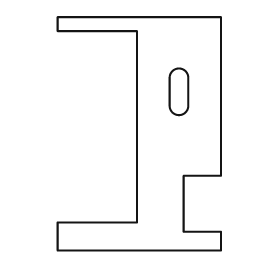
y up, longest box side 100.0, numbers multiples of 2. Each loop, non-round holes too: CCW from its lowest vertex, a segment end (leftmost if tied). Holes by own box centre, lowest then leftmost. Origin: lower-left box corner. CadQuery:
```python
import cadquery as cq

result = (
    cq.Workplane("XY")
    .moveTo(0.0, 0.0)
    .lineTo(70.0, 0.0)
    .lineTo(70.0, 8.0)
    .lineTo(54.0, 8.0)
    .lineTo(54.0, 32.0)
    .lineTo(70.0, 32.0)
    .lineTo(70.0, 100.0)
    .lineTo(0.0, 100.0)
    .lineTo(0.0, 94.0)
    .lineTo(34.0, 94.0)
    .lineTo(34.0, 12.0)
    .lineTo(0.0, 12.0)
    .close()
    .moveTo(48.0, 62.0)
    .threePointArc((52.0, 58.0), (56.0, 62.0))
    .lineTo(56.0, 74.0)
    .threePointArc((52.0, 78.0), (48.0, 74.0))
    .close()
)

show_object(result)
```